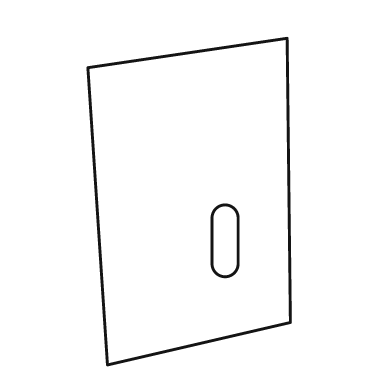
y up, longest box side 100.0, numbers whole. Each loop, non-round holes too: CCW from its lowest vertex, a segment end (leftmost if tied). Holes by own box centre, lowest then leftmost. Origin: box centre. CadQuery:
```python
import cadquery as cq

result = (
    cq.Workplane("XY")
    .moveTo(-25.0, -50.0)
    .lineTo(31.0, -37.0)
    .lineTo(30.0, 50.0)
    .lineTo(-31.0, 41.0)
    .close()
    .moveTo(7.0, -19.0)
    .threePointArc((11.0, -23.0), (15.0, -19.0))
    .lineTo(15.0, -5.0)
    .threePointArc((11.0, -1.0), (7.0, -5.0))
    .close()
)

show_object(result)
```